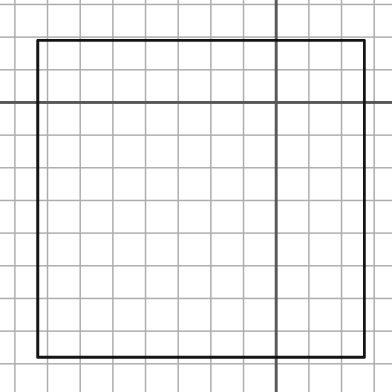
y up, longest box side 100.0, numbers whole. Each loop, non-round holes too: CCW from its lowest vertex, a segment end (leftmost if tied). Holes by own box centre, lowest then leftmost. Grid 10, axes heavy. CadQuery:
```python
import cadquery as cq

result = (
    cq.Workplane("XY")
    .moveTo(-73.0, -78.0)
    .lineTo(27.0, -78.0)
    .lineTo(27.0, 19.0)
    .lineTo(-73.0, 19.0)
    .close()
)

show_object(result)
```